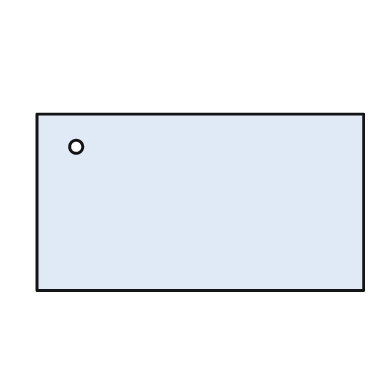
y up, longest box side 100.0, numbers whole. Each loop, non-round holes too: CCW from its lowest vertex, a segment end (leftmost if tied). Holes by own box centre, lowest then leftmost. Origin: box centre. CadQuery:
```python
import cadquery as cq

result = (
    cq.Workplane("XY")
    .moveTo(-50.0, -27.0)
    .lineTo(50.0, -27.0)
    .lineTo(50.0, 27.0)
    .lineTo(-50.0, 27.0)
    .close()
    .moveTo(-38.0, 17.0)
    .circle(2.0)
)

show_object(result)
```